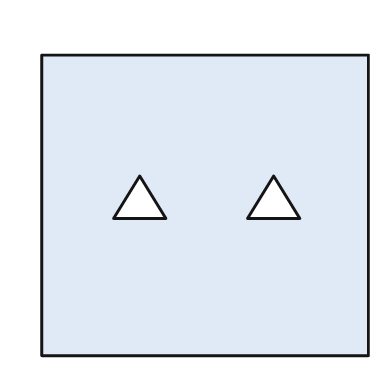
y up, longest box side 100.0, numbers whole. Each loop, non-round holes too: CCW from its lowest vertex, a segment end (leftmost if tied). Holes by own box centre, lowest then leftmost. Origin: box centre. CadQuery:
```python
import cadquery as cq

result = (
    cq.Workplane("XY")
    .moveTo(-50.0, -46.0)
    .lineTo(50.0, -46.0)
    .lineTo(50.0, 46.0)
    .lineTo(-50.0, 46.0)
    .close()
    .moveTo(-28.0, -4.0)
    .lineTo(-12.0, -4.0)
    .lineTo(-20.0, 9.0)
    .close()
    .moveTo(13.0, -4.0)
    .lineTo(29.0, -4.0)
    .lineTo(21.0, 9.0)
    .close()
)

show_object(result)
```